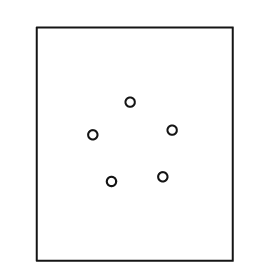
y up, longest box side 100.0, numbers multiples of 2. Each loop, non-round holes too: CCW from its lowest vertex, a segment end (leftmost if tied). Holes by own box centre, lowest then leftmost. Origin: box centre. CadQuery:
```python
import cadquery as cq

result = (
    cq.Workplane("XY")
    .moveTo(-42.0, -50.0)
    .lineTo(42.0, -50.0)
    .lineTo(42.0, 50.0)
    .lineTo(-42.0, 50.0)
    .close()
    .moveTo(-10.0, -16.0)
    .circle(2.0)
    .moveTo(12.0, -14.0)
    .circle(2.0)
    .moveTo(-18.0, 4.0)
    .circle(2.0)
    .moveTo(16.0, 6.0)
    .circle(2.0)
    .moveTo(-2.0, 18.0)
    .circle(2.0)
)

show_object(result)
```